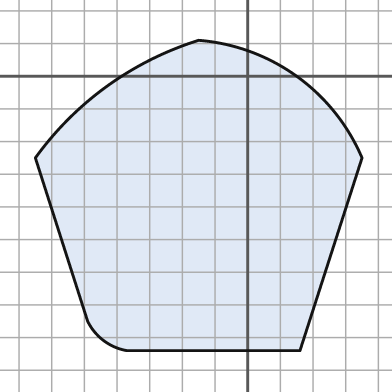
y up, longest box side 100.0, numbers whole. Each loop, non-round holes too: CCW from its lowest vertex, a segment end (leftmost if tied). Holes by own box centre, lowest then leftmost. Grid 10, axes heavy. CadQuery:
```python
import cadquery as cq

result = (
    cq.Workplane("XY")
    .moveTo(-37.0, -84.0)
    .lineTo(16.0, -84.0)
    .lineTo(35.0, -25.0)
    .threePointArc((15.0, 0.0), (-15.0, 11.0))
    .threePointArc((-43.0, -3.0), (-65.0, -25.0))
    .lineTo(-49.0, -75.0)
    .threePointArc((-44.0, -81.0), (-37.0, -84.0))
    .close()
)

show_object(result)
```